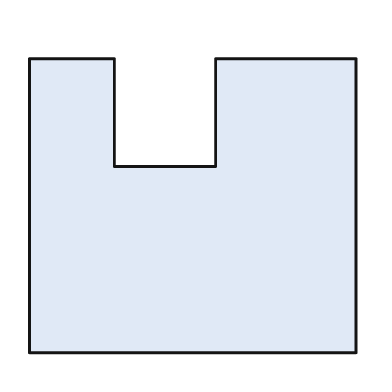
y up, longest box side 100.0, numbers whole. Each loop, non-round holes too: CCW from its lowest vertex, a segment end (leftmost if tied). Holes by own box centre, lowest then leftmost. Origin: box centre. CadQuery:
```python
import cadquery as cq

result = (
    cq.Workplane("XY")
    .moveTo(-50.0, -45.0)
    .lineTo(50.0, -45.0)
    .lineTo(50.0, 45.0)
    .lineTo(7.0, 45.0)
    .lineTo(7.0, 12.0)
    .lineTo(-24.0, 12.0)
    .lineTo(-24.0, 45.0)
    .lineTo(-50.0, 45.0)
    .close()
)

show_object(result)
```